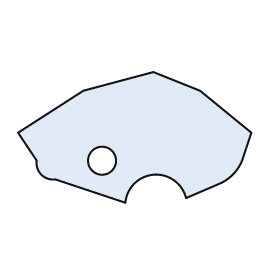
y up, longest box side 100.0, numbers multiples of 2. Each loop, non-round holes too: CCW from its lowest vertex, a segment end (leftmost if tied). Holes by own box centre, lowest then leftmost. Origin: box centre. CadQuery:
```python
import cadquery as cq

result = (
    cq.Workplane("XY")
    .moveTo(-4.0, -28.0)
    .threePointArc((8.0, -16.0), (22.0, -26.0))
    .lineTo(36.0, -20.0)
    .threePointArc((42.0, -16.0), (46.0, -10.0))
    .lineTo(50.0, 2.0)
    .lineTo(28.0, 20.0)
    .lineTo(8.0, 28.0)
    .lineTo(-22.0, 20.0)
    .lineTo(-50.0, 2.0)
    .lineTo(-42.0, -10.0)
    .threePointArc((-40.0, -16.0), (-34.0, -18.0))
    .close()
    .moveTo(-14.0, -10.0)
    .circle(6.0)
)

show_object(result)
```